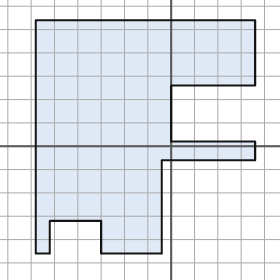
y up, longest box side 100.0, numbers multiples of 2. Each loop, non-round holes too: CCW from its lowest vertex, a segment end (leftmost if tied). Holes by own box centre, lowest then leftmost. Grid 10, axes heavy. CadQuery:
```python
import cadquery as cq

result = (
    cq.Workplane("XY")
    .moveTo(-58.0, -46.0)
    .lineTo(-52.0, -46.0)
    .lineTo(-52.0, -32.0)
    .lineTo(-30.0, -32.0)
    .lineTo(-30.0, -46.0)
    .lineTo(-4.0, -46.0)
    .lineTo(-4.0, -6.0)
    .lineTo(36.0, -6.0)
    .lineTo(36.0, 2.0)
    .lineTo(0.0, 2.0)
    .lineTo(0.0, 26.0)
    .lineTo(36.0, 26.0)
    .lineTo(36.0, 54.0)
    .lineTo(-58.0, 54.0)
    .close()
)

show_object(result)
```